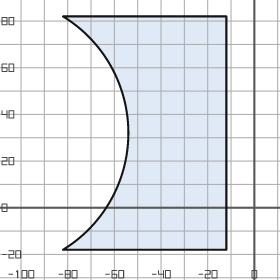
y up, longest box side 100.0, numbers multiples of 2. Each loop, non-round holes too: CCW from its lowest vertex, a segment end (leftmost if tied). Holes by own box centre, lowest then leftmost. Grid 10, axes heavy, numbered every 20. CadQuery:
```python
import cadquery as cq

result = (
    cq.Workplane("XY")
    .moveTo(-82.0, -18.0)
    .lineTo(-12.0, -18.0)
    .lineTo(-12.0, 82.0)
    .lineTo(-82.0, 82.0)
    .threePointArc((-54.0, 32.0), (-82.0, -18.0))
    .close()
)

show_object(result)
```